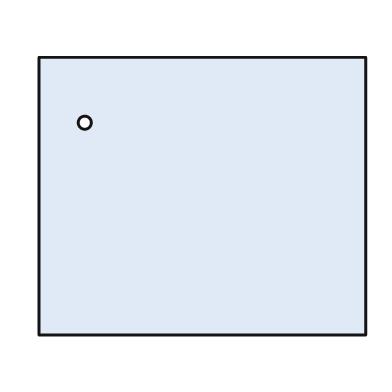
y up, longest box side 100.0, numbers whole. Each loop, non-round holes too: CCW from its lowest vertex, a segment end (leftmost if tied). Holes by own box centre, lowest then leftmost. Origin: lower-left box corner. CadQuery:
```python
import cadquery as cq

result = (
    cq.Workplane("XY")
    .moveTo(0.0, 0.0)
    .lineTo(100.0, 0.0)
    .lineTo(100.0, 85.0)
    .lineTo(0.0, 85.0)
    .close()
    .moveTo(14.0, 65.0)
    .circle(2.0)
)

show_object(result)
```